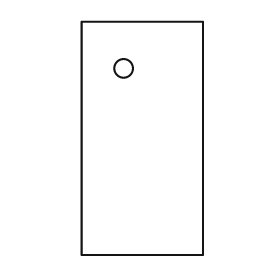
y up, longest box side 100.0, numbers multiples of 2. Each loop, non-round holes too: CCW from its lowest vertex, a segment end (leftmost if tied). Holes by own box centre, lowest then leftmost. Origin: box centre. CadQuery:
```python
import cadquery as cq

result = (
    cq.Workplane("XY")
    .moveTo(-26.0, -50.0)
    .lineTo(26.0, -50.0)
    .lineTo(26.0, 50.0)
    .lineTo(-26.0, 50.0)
    .close()
    .moveTo(-8.0, 30.0)
    .circle(4.0)
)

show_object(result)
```